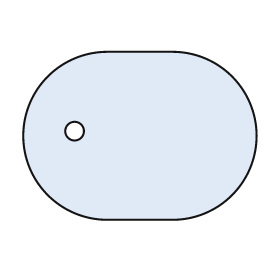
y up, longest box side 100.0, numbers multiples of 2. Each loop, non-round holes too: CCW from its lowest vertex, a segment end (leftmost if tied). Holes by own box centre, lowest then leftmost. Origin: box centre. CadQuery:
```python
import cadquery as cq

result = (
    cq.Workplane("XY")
    .moveTo(-14.0, -36.0)
    .lineTo(14.0, -36.0)
    .threePointArc((50.0, 0.0), (14.0, 36.0))
    .lineTo(-14.0, 36.0)
    .threePointArc((-50.0, 0.0), (-14.0, -36.0))
    .close()
    .moveTo(-28.0, 2.0)
    .circle(4.0)
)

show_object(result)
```